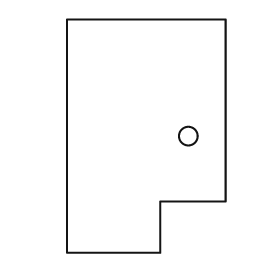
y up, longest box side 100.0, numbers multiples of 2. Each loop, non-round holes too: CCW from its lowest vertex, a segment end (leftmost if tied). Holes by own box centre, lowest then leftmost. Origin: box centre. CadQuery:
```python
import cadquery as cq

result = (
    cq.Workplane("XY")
    .moveTo(-34.0, -50.0)
    .lineTo(6.0, -50.0)
    .lineTo(6.0, -28.0)
    .lineTo(34.0, -28.0)
    .lineTo(34.0, 50.0)
    .lineTo(-34.0, 50.0)
    .close()
    .moveTo(18.0, 0.0)
    .circle(4.0)
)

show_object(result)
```